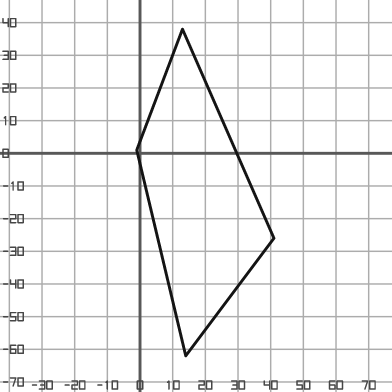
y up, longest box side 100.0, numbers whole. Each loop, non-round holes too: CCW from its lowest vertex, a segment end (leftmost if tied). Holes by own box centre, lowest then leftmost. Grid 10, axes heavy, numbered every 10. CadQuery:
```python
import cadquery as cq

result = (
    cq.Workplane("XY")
    .moveTo(14.0, -62.0)
    .lineTo(41.0, -26.0)
    .lineTo(13.0, 38.0)
    .lineTo(-1.0, 1.0)
    .close()
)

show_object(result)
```